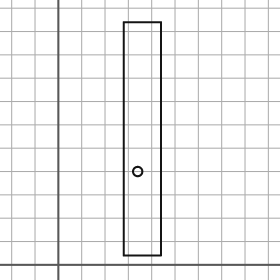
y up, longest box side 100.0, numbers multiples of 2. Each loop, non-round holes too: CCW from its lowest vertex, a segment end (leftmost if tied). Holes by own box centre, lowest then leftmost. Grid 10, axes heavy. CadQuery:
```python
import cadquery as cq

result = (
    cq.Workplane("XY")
    .moveTo(28.0, 4.0)
    .lineTo(44.0, 4.0)
    .lineTo(44.0, 104.0)
    .lineTo(28.0, 104.0)
    .close()
    .moveTo(34.0, 40.0)
    .circle(2.0)
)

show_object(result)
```